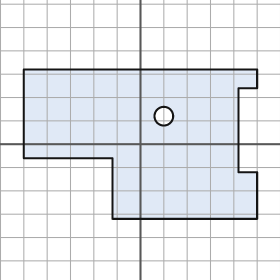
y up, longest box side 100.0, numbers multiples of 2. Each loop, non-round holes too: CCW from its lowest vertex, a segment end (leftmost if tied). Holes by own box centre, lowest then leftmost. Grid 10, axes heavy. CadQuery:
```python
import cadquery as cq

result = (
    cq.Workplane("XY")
    .moveTo(-12.0, -32.0)
    .lineTo(50.0, -32.0)
    .lineTo(50.0, -12.0)
    .lineTo(42.0, -12.0)
    .lineTo(42.0, 24.0)
    .lineTo(50.0, 24.0)
    .lineTo(50.0, 32.0)
    .lineTo(-50.0, 32.0)
    .lineTo(-50.0, -6.0)
    .lineTo(-12.0, -6.0)
    .close()
    .moveTo(10.0, 12.0)
    .circle(4.0)
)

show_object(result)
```